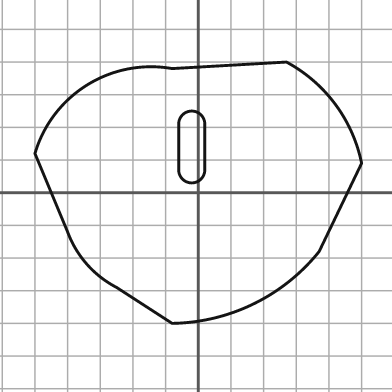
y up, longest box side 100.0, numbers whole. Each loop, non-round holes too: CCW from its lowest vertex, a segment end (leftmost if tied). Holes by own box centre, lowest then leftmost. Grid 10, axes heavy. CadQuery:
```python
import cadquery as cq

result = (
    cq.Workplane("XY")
    .moveTo(-8.0, -40.0)
    .threePointArc((17.0, -34.0), (37.0, -18.0))
    .lineTo(50.0, 9.0)
    .threePointArc((42.0, 27.0), (27.0, 40.0))
    .lineTo(-8.0, 38.0)
    .threePointArc((-34.0, 33.0), (-50.0, 12.0))
    .lineTo(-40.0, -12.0)
    .threePointArc((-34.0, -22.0), (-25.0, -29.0))
    .close()
    .moveTo(-6.0, 7.0)
    .threePointArc((-2.0, 3.0), (2.0, 7.0))
    .lineTo(2.0, 21.0)
    .threePointArc((-2.0, 25.0), (-6.0, 21.0))
    .close()
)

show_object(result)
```